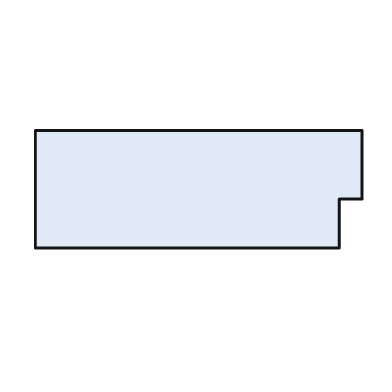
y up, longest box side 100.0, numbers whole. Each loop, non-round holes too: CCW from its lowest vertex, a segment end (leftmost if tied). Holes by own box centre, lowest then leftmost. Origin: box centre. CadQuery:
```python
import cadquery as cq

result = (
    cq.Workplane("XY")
    .moveTo(-50.0, -18.0)
    .lineTo(43.0, -18.0)
    .lineTo(43.0, -3.0)
    .lineTo(50.0, -3.0)
    .lineTo(50.0, 18.0)
    .lineTo(-50.0, 18.0)
    .close()
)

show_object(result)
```